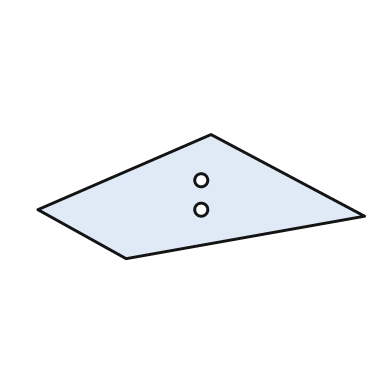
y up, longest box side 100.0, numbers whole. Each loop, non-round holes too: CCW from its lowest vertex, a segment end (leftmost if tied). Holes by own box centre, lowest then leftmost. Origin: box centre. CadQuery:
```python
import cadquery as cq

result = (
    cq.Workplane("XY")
    .moveTo(-23.0, -19.0)
    .lineTo(50.0, -6.0)
    .lineTo(3.0, 19.0)
    .lineTo(-50.0, -4.0)
    .close()
    .moveTo(0.0, -4.0)
    .circle(2.0)
    .moveTo(0.0, 5.0)
    .circle(2.0)
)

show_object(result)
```